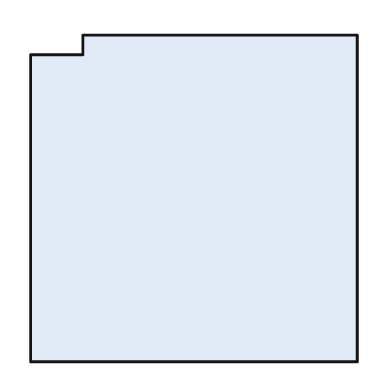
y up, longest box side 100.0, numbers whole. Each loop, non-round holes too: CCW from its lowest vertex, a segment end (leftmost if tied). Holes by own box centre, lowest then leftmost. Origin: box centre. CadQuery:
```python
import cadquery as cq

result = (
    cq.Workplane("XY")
    .moveTo(-50.0, -50.0)
    .lineTo(50.0, -50.0)
    .lineTo(50.0, 50.0)
    .lineTo(-34.0, 50.0)
    .lineTo(-34.0, 44.0)
    .lineTo(-50.0, 44.0)
    .close()
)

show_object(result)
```